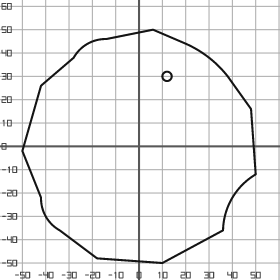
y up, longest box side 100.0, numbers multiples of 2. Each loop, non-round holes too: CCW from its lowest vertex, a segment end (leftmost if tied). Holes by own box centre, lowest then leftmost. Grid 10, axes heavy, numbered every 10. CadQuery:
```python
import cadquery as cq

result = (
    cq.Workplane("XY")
    .moveTo(10.0, -50.0)
    .lineTo(36.0, -36.0)
    .threePointArc((40.0, -22.0), (50.0, -12.0))
    .lineTo(48.0, 16.0)
    .lineTo(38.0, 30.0)
    .threePointArc((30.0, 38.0), (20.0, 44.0))
    .lineTo(6.0, 50.0)
    .lineTo(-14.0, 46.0)
    .threePointArc((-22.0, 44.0), (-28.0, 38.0))
    .lineTo(-42.0, 26.0)
    .lineTo(-50.0, -2.0)
    .lineTo(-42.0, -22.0)
    .threePointArc((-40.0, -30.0), (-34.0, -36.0))
    .lineTo(-18.0, -48.0)
    .close()
    .moveTo(12.0, 30.0)
    .circle(2.0)
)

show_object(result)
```